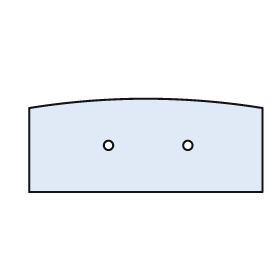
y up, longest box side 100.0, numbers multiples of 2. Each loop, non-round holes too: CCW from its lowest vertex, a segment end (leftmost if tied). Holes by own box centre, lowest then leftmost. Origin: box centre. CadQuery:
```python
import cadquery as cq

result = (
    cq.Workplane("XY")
    .moveTo(-50.0, -20.0)
    .lineTo(50.0, -20.0)
    .lineTo(50.0, 16.0)
    .threePointArc((0.0, 20.0), (-50.0, 16.0))
    .close()
    .moveTo(-16.0, 0.0)
    .circle(2.0)
    .moveTo(18.0, 0.0)
    .circle(2.0)
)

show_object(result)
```